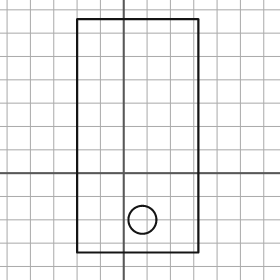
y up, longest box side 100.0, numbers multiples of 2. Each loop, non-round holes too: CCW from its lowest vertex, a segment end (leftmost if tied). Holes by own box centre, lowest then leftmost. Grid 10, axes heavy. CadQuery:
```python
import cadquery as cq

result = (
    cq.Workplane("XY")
    .moveTo(-20.0, -34.0)
    .lineTo(32.0, -34.0)
    .lineTo(32.0, 66.0)
    .lineTo(-20.0, 66.0)
    .close()
    .moveTo(8.0, -20.0)
    .circle(6.0)
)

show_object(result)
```